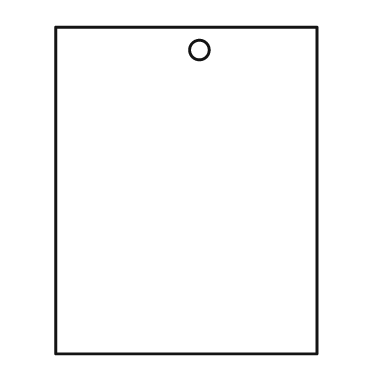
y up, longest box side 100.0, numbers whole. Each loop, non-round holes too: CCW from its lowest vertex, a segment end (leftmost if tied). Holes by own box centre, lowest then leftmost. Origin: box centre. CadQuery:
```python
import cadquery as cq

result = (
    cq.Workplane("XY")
    .moveTo(-40.0, -50.0)
    .lineTo(40.0, -50.0)
    .lineTo(40.0, 50.0)
    .lineTo(-40.0, 50.0)
    .close()
    .moveTo(4.0, 43.0)
    .circle(3.0)
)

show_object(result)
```